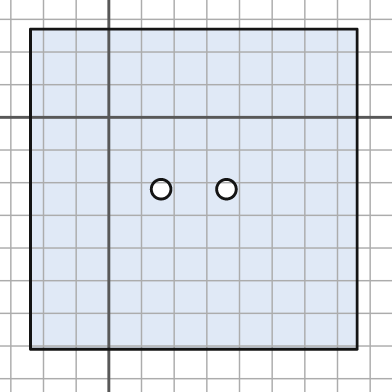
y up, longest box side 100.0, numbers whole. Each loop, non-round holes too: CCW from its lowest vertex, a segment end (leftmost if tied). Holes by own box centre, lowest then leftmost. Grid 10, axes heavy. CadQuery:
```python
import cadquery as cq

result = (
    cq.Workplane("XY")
    .moveTo(-24.0, -71.0)
    .lineTo(76.0, -71.0)
    .lineTo(76.0, 27.0)
    .lineTo(-24.0, 27.0)
    .close()
    .moveTo(16.0, -22.0)
    .circle(3.0)
    .moveTo(36.0, -22.0)
    .circle(3.0)
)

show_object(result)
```